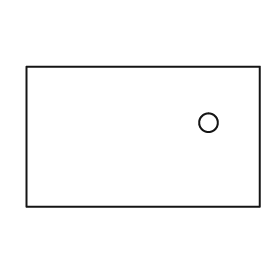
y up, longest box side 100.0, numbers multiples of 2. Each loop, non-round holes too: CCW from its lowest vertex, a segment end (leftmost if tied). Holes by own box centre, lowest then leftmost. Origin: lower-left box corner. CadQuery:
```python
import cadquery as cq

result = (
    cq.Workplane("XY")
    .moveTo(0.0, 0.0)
    .lineTo(100.0, 0.0)
    .lineTo(100.0, 60.0)
    .lineTo(0.0, 60.0)
    .close()
    .moveTo(78.0, 36.0)
    .circle(4.0)
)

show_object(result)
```